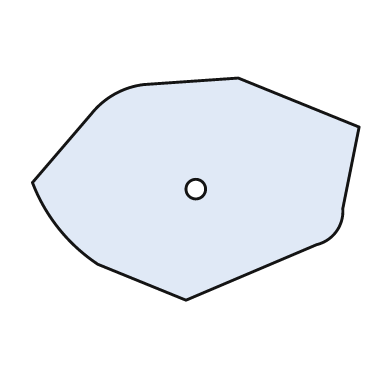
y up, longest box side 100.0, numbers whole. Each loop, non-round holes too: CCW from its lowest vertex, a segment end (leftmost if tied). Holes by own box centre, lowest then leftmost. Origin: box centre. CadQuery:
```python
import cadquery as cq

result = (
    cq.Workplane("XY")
    .moveTo(-3.0, -34.0)
    .lineTo(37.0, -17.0)
    .threePointArc((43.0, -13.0), (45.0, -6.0))
    .lineTo(50.0, 19.0)
    .lineTo(13.0, 34.0)
    .lineTo(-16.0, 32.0)
    .threePointArc((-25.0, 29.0), (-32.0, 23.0))
    .lineTo(-50.0, 2.0)
    .threePointArc((-42.0, -12.0), (-30.0, -23.0))
    .close()
    .moveTo(0.0, 0.0)
    .circle(3.0)
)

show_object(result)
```